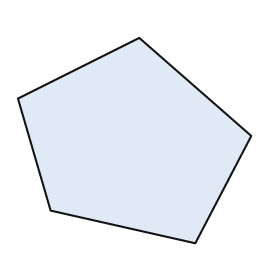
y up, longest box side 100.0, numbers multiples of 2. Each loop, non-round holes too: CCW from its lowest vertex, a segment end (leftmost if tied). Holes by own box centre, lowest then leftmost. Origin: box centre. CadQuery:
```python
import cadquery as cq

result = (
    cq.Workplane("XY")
    .moveTo(26.0, -44.0)
    .lineTo(50.0, 2.0)
    .lineTo(2.0, 44.0)
    .lineTo(-50.0, 18.0)
    .lineTo(-36.0, -30.0)
    .close()
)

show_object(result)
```